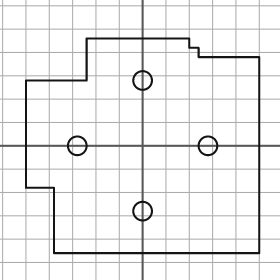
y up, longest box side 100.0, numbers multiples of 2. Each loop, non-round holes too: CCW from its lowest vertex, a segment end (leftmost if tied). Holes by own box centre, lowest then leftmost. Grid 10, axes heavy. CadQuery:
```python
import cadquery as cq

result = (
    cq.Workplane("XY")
    .moveTo(-38.0, -46.0)
    .lineTo(50.0, -46.0)
    .lineTo(50.0, 38.0)
    .lineTo(24.0, 38.0)
    .lineTo(24.0, 42.0)
    .lineTo(20.0, 42.0)
    .lineTo(20.0, 46.0)
    .lineTo(-24.0, 46.0)
    .lineTo(-24.0, 28.0)
    .lineTo(-50.0, 28.0)
    .lineTo(-50.0, -18.0)
    .lineTo(-38.0, -18.0)
    .close()
    .moveTo(0.0, -28.0)
    .circle(4.0)
    .moveTo(-28.0, 0.0)
    .circle(4.0)
    .moveTo(28.0, 0.0)
    .circle(4.0)
    .moveTo(0.0, 28.0)
    .circle(4.0)
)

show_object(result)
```